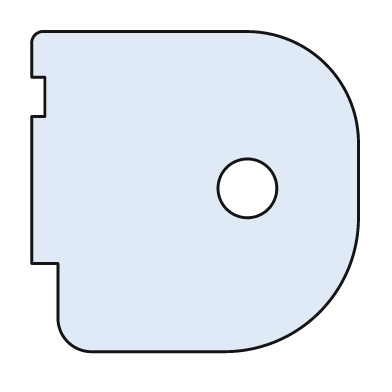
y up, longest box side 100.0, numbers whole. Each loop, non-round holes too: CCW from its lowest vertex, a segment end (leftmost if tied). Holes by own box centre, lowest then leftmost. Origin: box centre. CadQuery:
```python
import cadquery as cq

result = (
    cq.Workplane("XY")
    .moveTo(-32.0, -49.0)
    .lineTo(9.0, -49.0)
    .threePointArc((38.0, -37.0), (50.0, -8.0))
    .lineTo(50.0, 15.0)
    .threePointArc((40.0, 39.0), (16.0, 49.0))
    .lineTo(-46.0, 49.0)
    .threePointArc((-49.0, 48.0), (-50.0, 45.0))
    .lineTo(-50.0, 35.0)
    .lineTo(-46.0, 35.0)
    .lineTo(-46.0, 23.0)
    .lineTo(-50.0, 23.0)
    .lineTo(-50.0, -22.0)
    .lineTo(-42.0, -22.0)
    .lineTo(-42.0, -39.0)
    .threePointArc((-39.0, -46.0), (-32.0, -49.0))
    .close()
    .moveTo(16.0, 1.0)
    .circle(9.0)
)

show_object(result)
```